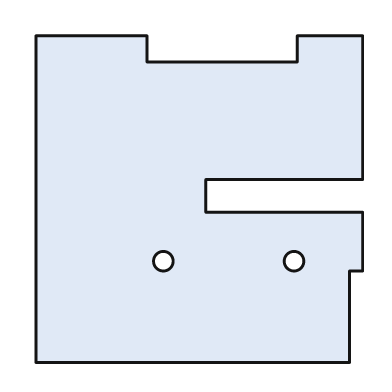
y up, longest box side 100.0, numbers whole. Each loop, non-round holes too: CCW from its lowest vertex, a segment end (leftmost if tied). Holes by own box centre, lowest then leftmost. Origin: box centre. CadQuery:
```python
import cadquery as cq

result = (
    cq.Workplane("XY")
    .moveTo(-50.0, -50.0)
    .lineTo(46.0, -50.0)
    .lineTo(46.0, -22.0)
    .lineTo(50.0, -22.0)
    .lineTo(50.0, -4.0)
    .lineTo(2.0, -4.0)
    .lineTo(2.0, 6.0)
    .lineTo(50.0, 6.0)
    .lineTo(50.0, 50.0)
    .lineTo(30.0, 50.0)
    .lineTo(30.0, 42.0)
    .lineTo(-16.0, 42.0)
    .lineTo(-16.0, 50.0)
    .lineTo(-50.0, 50.0)
    .close()
    .moveTo(-11.0, -19.0)
    .circle(3.0)
    .moveTo(29.0, -19.0)
    .circle(3.0)
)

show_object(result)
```